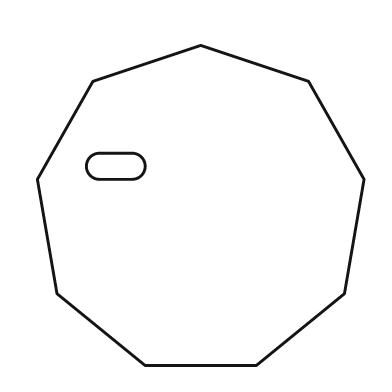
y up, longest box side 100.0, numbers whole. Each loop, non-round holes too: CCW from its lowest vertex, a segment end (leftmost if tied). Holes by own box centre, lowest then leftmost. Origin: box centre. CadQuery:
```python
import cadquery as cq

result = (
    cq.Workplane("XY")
    .moveTo(-17.0, -49.0)
    .lineTo(17.0, -49.0)
    .lineTo(44.0, -27.0)
    .lineTo(50.0, 8.0)
    .lineTo(33.0, 38.0)
    .lineTo(0.0, 49.0)
    .lineTo(-33.0, 38.0)
    .lineTo(-50.0, 8.0)
    .lineTo(-44.0, -27.0)
    .close()
    .moveTo(-31.0, 8.0)
    .lineTo(-21.0, 8.0)
    .threePointArc((-17.0, 12.0), (-21.0, 16.0))
    .lineTo(-31.0, 16.0)
    .threePointArc((-35.0, 12.0), (-31.0, 8.0))
    .close()
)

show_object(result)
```